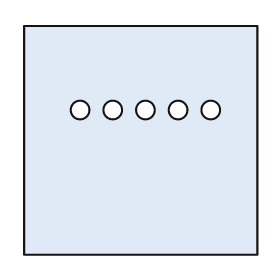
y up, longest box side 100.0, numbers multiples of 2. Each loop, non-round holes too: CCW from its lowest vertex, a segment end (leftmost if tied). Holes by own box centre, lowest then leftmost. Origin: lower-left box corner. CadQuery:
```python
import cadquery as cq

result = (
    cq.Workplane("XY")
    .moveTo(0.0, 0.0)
    .lineTo(100.0, 0.0)
    .lineTo(100.0, 98.0)
    .lineTo(0.0, 98.0)
    .close()
    .moveTo(24.0, 62.0)
    .circle(4.0)
    .moveTo(38.0, 62.0)
    .circle(4.0)
    .moveTo(52.0, 62.0)
    .circle(4.0)
    .moveTo(66.0, 62.0)
    .circle(4.0)
    .moveTo(80.0, 62.0)
    .circle(4.0)
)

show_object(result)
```